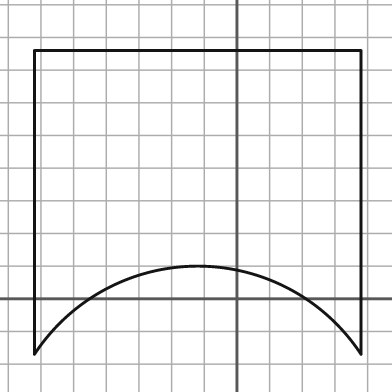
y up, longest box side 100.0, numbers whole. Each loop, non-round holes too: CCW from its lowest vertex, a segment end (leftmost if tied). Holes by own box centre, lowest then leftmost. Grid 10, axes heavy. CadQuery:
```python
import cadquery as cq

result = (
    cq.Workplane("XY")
    .moveTo(-62.0, -17.0)
    .threePointArc((-12.0, 10.0), (38.0, -17.0))
    .lineTo(38.0, 76.0)
    .lineTo(-62.0, 76.0)
    .close()
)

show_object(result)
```